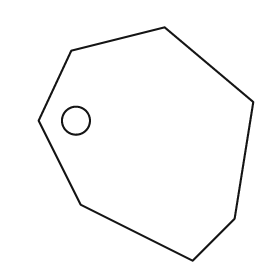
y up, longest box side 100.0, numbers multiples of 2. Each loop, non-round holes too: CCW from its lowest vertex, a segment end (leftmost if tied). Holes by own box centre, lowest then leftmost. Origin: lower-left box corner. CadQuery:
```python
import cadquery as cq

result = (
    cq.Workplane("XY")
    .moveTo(66.0, 0.0)
    .lineTo(84.0, 18.0)
    .lineTo(92.0, 68.0)
    .lineTo(54.0, 100.0)
    .lineTo(14.0, 90.0)
    .lineTo(0.0, 60.0)
    .lineTo(18.0, 24.0)
    .close()
    .moveTo(16.0, 60.0)
    .circle(6.0)
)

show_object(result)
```